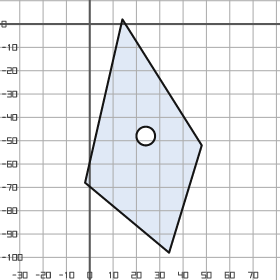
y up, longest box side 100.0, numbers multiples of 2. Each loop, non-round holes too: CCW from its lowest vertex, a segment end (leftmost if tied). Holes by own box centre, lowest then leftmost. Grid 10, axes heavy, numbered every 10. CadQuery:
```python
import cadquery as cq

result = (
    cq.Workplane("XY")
    .moveTo(34.0, -98.0)
    .lineTo(48.0, -52.0)
    .lineTo(14.0, 2.0)
    .lineTo(-2.0, -68.0)
    .close()
    .moveTo(24.0, -48.0)
    .circle(4.0)
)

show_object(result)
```